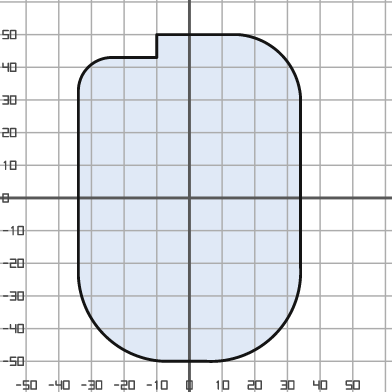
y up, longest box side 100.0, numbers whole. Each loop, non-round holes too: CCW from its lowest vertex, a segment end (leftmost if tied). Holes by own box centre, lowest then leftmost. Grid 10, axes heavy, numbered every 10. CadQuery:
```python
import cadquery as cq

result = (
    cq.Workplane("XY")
    .moveTo(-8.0, -50.0)
    .lineTo(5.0, -50.0)
    .threePointArc((26.0, -42.0), (34.0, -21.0))
    .lineTo(34.0, 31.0)
    .threePointArc((28.0, 44.0), (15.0, 50.0))
    .lineTo(-10.0, 50.0)
    .lineTo(-10.0, 43.0)
    .lineTo(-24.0, 43.0)
    .threePointArc((-31.0, 40.0), (-34.0, 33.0))
    .lineTo(-34.0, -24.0)
    .threePointArc((-26.0, -42.0), (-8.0, -50.0))
    .close()
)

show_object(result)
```